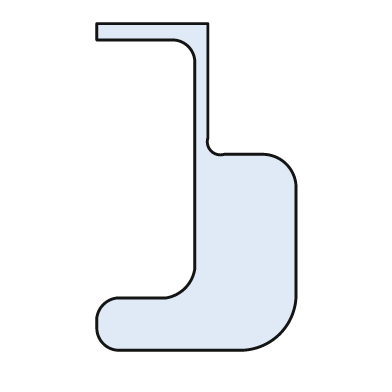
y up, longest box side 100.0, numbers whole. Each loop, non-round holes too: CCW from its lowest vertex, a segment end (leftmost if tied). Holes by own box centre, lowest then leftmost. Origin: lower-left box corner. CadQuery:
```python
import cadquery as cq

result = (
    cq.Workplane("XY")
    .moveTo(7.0, 0.0)
    .lineTo(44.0, 0.0)
    .threePointArc((56.0, 5.0), (61.0, 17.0))
    .lineTo(61.0, 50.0)
    .threePointArc((58.0, 57.0), (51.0, 60.0))
    .lineTo(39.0, 60.0)
    .threePointArc((35.0, 61.0), (34.0, 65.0))
    .lineTo(34.0, 100.0)
    .lineTo(0.0, 100.0)
    .lineTo(0.0, 95.0)
    .lineTo(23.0, 95.0)
    .threePointArc((28.0, 93.0), (30.0, 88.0))
    .lineTo(30.0, 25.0)
    .threePointArc((27.0, 19.0), (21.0, 16.0))
    .lineTo(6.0, 16.0)
    .threePointArc((2.0, 14.0), (0.0, 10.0))
    .lineTo(0.0, 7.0)
    .threePointArc((2.0, 2.0), (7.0, 0.0))
    .close()
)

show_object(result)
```